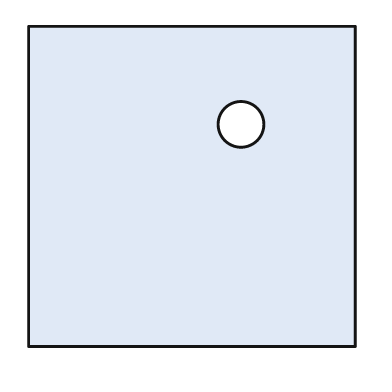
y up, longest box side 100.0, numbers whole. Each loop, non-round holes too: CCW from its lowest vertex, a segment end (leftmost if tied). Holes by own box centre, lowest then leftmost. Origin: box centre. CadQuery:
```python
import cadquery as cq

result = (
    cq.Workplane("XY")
    .moveTo(-50.0, -49.0)
    .lineTo(50.0, -49.0)
    .lineTo(50.0, 49.0)
    .lineTo(-50.0, 49.0)
    .close()
    .moveTo(15.0, 19.0)
    .circle(7.0)
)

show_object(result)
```